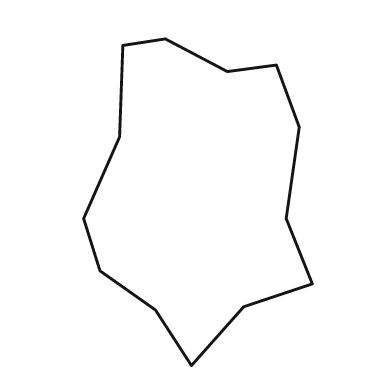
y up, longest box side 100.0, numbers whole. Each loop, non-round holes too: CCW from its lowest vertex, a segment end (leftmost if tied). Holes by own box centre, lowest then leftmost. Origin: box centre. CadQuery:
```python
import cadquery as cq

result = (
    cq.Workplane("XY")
    .moveTo(-2.0, -50.0)
    .lineTo(14.0, -32.0)
    .lineTo(35.0, -25.0)
    .lineTo(27.0, -5.0)
    .lineTo(31.0, 23.0)
    .lineTo(24.0, 42.0)
    .lineTo(9.0, 40.0)
    .lineTo(-10.0, 50.0)
    .lineTo(-23.0, 48.0)
    .lineTo(-24.0, 20.0)
    .lineTo(-35.0, -5.0)
    .lineTo(-30.0, -21.0)
    .lineTo(-13.0, -33.0)
    .close()
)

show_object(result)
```